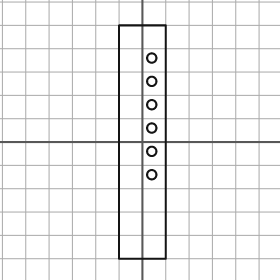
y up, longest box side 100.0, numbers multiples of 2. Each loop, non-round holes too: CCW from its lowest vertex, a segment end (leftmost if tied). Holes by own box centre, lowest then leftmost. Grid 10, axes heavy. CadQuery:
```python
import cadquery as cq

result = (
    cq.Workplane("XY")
    .moveTo(-10.0, -50.0)
    .lineTo(10.0, -50.0)
    .lineTo(10.0, 50.0)
    .lineTo(-10.0, 50.0)
    .close()
    .moveTo(4.0, -14.0)
    .circle(2.0)
    .moveTo(4.0, -4.0)
    .circle(2.0)
    .moveTo(4.0, 6.0)
    .circle(2.0)
    .moveTo(4.0, 16.0)
    .circle(2.0)
    .moveTo(4.0, 26.0)
    .circle(2.0)
    .moveTo(4.0, 36.0)
    .circle(2.0)
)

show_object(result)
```